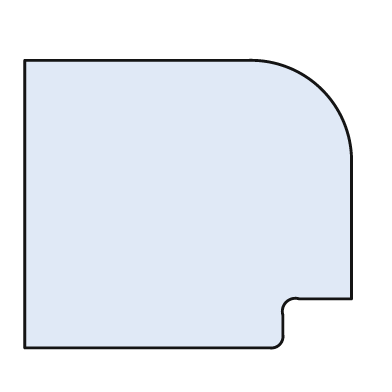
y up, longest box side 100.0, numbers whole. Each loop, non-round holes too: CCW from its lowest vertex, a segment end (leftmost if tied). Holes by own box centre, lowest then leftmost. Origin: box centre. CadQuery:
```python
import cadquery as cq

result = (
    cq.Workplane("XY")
    .moveTo(-50.0, -44.0)
    .lineTo(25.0, -44.0)
    .threePointArc((28.0, -43.0), (29.0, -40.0))
    .lineTo(29.0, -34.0)
    .threePointArc((30.0, -30.0), (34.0, -29.0))
    .lineTo(50.0, -29.0)
    .lineTo(50.0, 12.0)
    .threePointArc((41.0, 35.0), (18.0, 44.0))
    .lineTo(-50.0, 44.0)
    .close()
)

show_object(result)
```